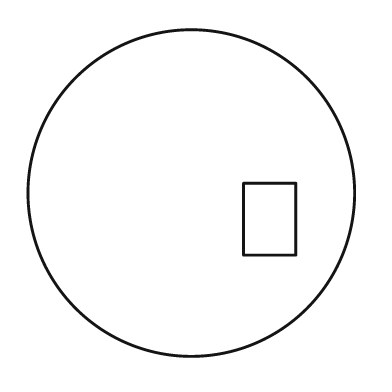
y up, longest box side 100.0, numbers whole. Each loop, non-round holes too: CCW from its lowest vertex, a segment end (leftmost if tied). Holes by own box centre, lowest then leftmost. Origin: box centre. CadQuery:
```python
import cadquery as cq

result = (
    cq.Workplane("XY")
    .moveTo(0.0, 0.0)
    .circle(50.0)
    .moveTo(16.0, -19.0)
    .lineTo(32.0, -19.0)
    .lineTo(32.0, 3.0)
    .lineTo(16.0, 3.0)
    .close()
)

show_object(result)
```